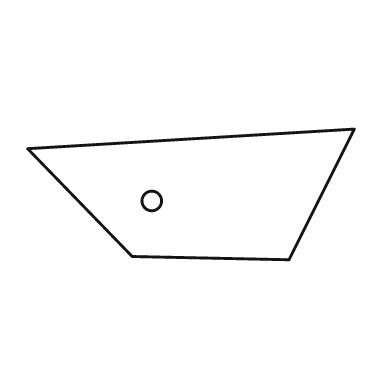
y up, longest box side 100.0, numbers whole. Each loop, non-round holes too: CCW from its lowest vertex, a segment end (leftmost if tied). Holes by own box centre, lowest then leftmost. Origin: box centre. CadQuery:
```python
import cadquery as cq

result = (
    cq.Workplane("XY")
    .moveTo(30.0, -20.0)
    .lineTo(50.0, 20.0)
    .lineTo(-50.0, 14.0)
    .lineTo(-18.0, -19.0)
    .close()
    .moveTo(-12.0, -2.0)
    .circle(3.0)
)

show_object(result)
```